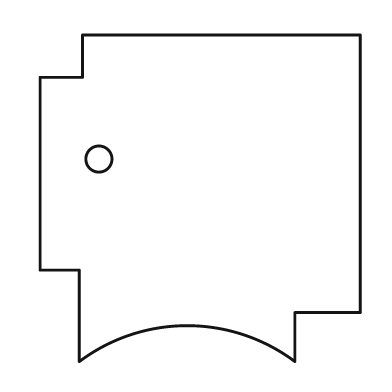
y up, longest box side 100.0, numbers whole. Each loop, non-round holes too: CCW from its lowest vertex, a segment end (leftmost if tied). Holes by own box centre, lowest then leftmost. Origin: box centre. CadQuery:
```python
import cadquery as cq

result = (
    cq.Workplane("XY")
    .moveTo(-37.0, -50.0)
    .threePointArc((-4.0, -39.0), (29.0, -50.0))
    .lineTo(29.0, -35.0)
    .lineTo(49.0, -35.0)
    .lineTo(49.0, 50.0)
    .lineTo(-36.0, 50.0)
    .lineTo(-36.0, 37.0)
    .lineTo(-49.0, 37.0)
    .lineTo(-49.0, -22.0)
    .lineTo(-37.0, -22.0)
    .close()
    .moveTo(-31.0, 12.0)
    .circle(4.0)
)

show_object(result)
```